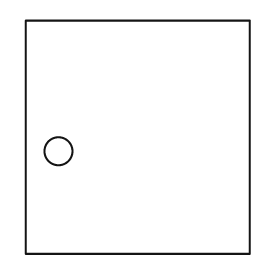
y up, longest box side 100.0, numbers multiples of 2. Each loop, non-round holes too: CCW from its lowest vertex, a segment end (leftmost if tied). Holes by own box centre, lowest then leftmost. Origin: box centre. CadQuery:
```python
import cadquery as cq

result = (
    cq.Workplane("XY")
    .moveTo(-48.0, -50.0)
    .lineTo(48.0, -50.0)
    .lineTo(48.0, 50.0)
    .lineTo(-48.0, 50.0)
    .close()
    .moveTo(-34.0, -6.0)
    .circle(6.0)
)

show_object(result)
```